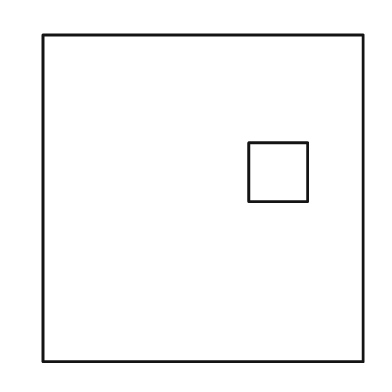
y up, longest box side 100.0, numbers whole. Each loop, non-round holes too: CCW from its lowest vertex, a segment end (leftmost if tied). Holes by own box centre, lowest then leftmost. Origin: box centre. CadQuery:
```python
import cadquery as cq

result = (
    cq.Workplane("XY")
    .moveTo(-49.0, -50.0)
    .lineTo(49.0, -50.0)
    .lineTo(49.0, 50.0)
    .lineTo(-49.0, 50.0)
    .close()
    .moveTo(14.0, -1.0)
    .lineTo(32.0, -1.0)
    .lineTo(32.0, 17.0)
    .lineTo(14.0, 17.0)
    .close()
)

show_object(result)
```